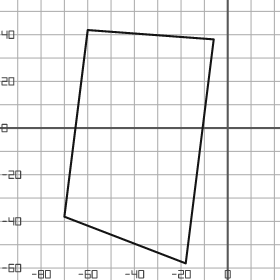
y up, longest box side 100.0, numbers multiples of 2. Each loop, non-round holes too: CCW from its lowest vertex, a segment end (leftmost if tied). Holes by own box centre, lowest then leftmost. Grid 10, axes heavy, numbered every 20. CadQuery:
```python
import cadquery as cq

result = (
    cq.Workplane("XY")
    .moveTo(-18.0, -58.0)
    .lineTo(-6.0, 38.0)
    .lineTo(-60.0, 42.0)
    .lineTo(-70.0, -38.0)
    .close()
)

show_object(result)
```